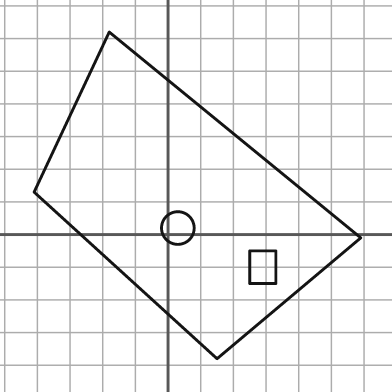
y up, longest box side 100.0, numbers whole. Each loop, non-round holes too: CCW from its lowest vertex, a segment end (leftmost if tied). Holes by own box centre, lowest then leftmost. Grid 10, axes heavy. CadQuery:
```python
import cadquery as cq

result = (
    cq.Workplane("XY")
    .moveTo(15.0, -38.0)
    .lineTo(59.0, -1.0)
    .lineTo(-18.0, 62.0)
    .lineTo(-41.0, 13.0)
    .close()
    .moveTo(25.0, -15.0)
    .lineTo(33.0, -15.0)
    .lineTo(33.0, -5.0)
    .lineTo(25.0, -5.0)
    .close()
    .moveTo(3.0, 2.0)
    .circle(5.0)
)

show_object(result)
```